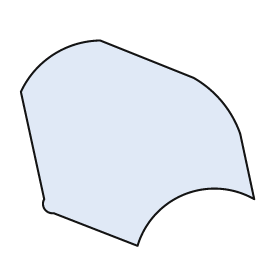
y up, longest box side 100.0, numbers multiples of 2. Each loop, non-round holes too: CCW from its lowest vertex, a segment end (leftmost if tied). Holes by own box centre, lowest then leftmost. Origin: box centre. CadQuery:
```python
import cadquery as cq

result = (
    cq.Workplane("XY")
    .moveTo(0.0, -44.0)
    .threePointArc((20.0, -22.0), (50.0, -24.0))
    .lineTo(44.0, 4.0)
    .threePointArc((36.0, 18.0), (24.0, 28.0))
    .lineTo(-16.0, 44.0)
    .threePointArc((-36.0, 38.0), (-50.0, 22.0))
    .lineTo(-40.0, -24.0)
    .threePointArc((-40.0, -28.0), (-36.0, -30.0))
    .close()
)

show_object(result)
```